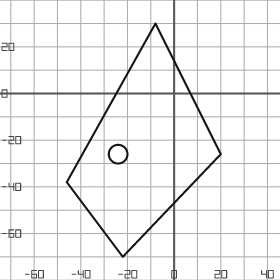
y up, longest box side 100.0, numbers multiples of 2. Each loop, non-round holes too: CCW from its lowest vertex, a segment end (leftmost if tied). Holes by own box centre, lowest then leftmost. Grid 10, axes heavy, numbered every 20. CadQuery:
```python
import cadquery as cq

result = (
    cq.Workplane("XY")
    .moveTo(-22.0, -70.0)
    .lineTo(20.0, -26.0)
    .lineTo(-8.0, 30.0)
    .lineTo(-46.0, -38.0)
    .close()
    .moveTo(-24.0, -26.0)
    .circle(4.0)
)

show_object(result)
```